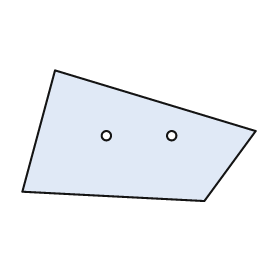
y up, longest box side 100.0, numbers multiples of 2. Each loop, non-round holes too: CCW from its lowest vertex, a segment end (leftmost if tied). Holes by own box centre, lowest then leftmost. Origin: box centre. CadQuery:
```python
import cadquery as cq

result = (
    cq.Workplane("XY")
    .moveTo(28.0, -28.0)
    .lineTo(50.0, 2.0)
    .lineTo(-36.0, 28.0)
    .lineTo(-50.0, -24.0)
    .close()
    .moveTo(-14.0, 0.0)
    .circle(2.0)
    .moveTo(14.0, 0.0)
    .circle(2.0)
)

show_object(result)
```